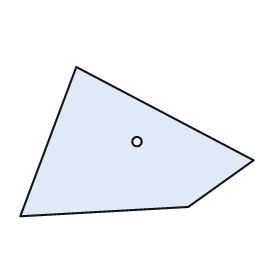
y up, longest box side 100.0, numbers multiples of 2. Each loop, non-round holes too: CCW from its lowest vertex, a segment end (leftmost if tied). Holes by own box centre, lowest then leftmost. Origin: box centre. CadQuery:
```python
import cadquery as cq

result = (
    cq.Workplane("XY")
    .moveTo(-50.0, -32.0)
    .lineTo(22.0, -28.0)
    .lineTo(50.0, -8.0)
    .lineTo(-26.0, 32.0)
    .close()
    .moveTo(0.0, 0.0)
    .circle(2.0)
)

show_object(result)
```